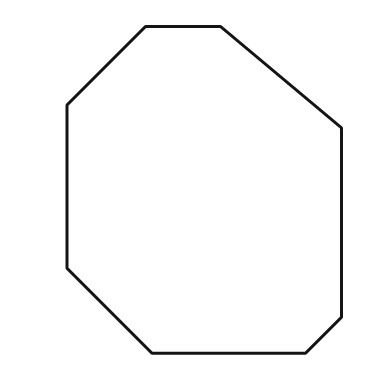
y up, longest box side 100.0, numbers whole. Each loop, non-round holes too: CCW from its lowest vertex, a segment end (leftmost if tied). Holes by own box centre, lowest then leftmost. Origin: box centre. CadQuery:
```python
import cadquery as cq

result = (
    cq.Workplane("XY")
    .moveTo(-16.0, -50.0)
    .lineTo(31.0, -50.0)
    .lineTo(42.0, -39.0)
    .lineTo(42.0, 19.0)
    .lineTo(5.0, 50.0)
    .lineTo(-18.0, 50.0)
    .lineTo(-42.0, 26.0)
    .lineTo(-42.0, -24.0)
    .close()
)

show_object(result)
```